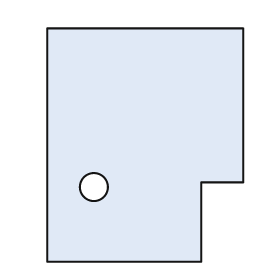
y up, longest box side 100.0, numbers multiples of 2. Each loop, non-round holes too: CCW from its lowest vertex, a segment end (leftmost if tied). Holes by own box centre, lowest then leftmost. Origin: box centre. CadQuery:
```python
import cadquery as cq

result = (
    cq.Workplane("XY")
    .moveTo(-42.0, -50.0)
    .lineTo(24.0, -50.0)
    .lineTo(24.0, -16.0)
    .lineTo(42.0, -16.0)
    .lineTo(42.0, 50.0)
    .lineTo(-42.0, 50.0)
    .close()
    .moveTo(-22.0, -18.0)
    .circle(6.0)
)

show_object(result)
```